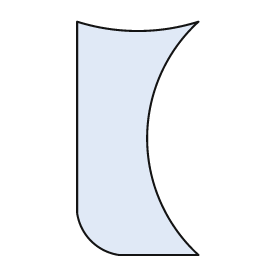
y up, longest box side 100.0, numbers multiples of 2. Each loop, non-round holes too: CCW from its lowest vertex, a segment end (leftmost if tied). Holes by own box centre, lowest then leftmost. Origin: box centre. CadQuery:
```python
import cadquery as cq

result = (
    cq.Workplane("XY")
    .moveTo(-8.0, -50.0)
    .lineTo(26.0, -50.0)
    .threePointArc((4.0, 0.0), (26.0, 50.0))
    .threePointArc((0.0, 46.0), (-26.0, 50.0))
    .lineTo(-26.0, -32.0)
    .threePointArc((-20.0, -44.0), (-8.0, -50.0))
    .close()
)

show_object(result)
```